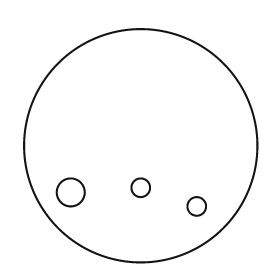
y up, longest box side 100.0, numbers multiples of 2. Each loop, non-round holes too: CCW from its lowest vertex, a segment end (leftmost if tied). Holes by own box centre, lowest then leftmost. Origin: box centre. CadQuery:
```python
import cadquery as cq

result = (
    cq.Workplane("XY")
    .moveTo(0.0, 0.0)
    .circle(50.0)
    .moveTo(24.0, -26.0)
    .circle(4.0)
    .moveTo(-30.0, -20.0)
    .circle(6.0)
    .moveTo(0.0, -18.0)
    .circle(4.0)
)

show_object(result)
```